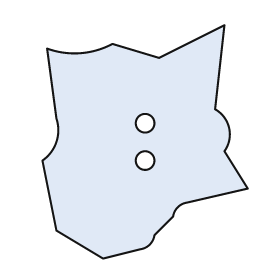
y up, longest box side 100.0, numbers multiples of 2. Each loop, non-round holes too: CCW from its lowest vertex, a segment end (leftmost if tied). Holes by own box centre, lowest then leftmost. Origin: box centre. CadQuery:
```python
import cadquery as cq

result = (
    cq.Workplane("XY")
    .moveTo(-18.0, -50.0)
    .lineTo(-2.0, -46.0)
    .threePointArc((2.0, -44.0), (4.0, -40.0))
    .lineTo(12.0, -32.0)
    .threePointArc((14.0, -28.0), (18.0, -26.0))
    .lineTo(44.0, -20.0)
    .lineTo(34.0, -4.0)
    .threePointArc((36.0, 6.0), (30.0, 14.0))
    .lineTo(34.0, 50.0)
    .lineTo(6.0, 36.0)
    .lineTo(-14.0, 42.0)
    .threePointArc((-28.0, 38.0), (-42.0, 40.0))
    .lineTo(-38.0, 10.0)
    .threePointArc((-38.0, 0.0), (-44.0, -8.0))
    .lineTo(-38.0, -38.0)
    .close()
    .moveTo(0.0, -8.0)
    .circle(4.0)
    .moveTo(0.0, 8.0)
    .circle(4.0)
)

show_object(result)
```